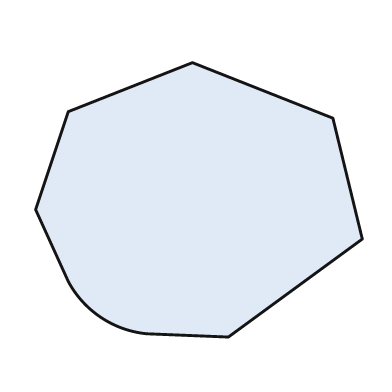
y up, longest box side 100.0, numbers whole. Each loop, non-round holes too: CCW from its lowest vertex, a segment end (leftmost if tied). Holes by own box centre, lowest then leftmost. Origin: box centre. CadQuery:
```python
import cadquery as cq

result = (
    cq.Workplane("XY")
    .moveTo(9.0, -42.0)
    .lineTo(50.0, -12.0)
    .lineTo(41.0, 25.0)
    .lineTo(-2.0, 42.0)
    .lineTo(-40.0, 27.0)
    .lineTo(-50.0, -3.0)
    .lineTo(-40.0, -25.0)
    .threePointArc((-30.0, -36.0), (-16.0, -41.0))
    .close()
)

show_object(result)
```